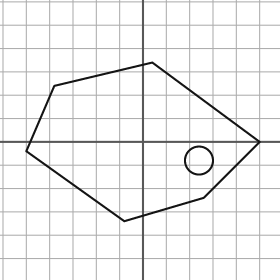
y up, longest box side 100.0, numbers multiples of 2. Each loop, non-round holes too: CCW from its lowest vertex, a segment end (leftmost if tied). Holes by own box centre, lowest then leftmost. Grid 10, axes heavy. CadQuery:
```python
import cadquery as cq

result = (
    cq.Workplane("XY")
    .moveTo(-8.0, -34.0)
    .lineTo(26.0, -24.0)
    .lineTo(50.0, 0.0)
    .lineTo(4.0, 34.0)
    .lineTo(-38.0, 24.0)
    .lineTo(-50.0, -4.0)
    .close()
    .moveTo(24.0, -8.0)
    .circle(6.0)
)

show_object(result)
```